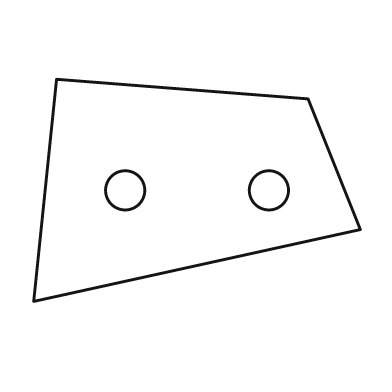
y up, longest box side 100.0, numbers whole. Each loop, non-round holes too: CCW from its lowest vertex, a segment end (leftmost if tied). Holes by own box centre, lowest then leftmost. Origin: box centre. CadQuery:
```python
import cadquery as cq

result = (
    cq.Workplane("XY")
    .moveTo(-50.0, -34.0)
    .lineTo(50.0, -12.0)
    .lineTo(34.0, 28.0)
    .lineTo(-43.0, 34.0)
    .close()
    .moveTo(-22.0, 0.0)
    .circle(6.0)
    .moveTo(22.0, 0.0)
    .circle(6.0)
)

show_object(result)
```